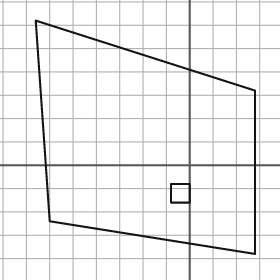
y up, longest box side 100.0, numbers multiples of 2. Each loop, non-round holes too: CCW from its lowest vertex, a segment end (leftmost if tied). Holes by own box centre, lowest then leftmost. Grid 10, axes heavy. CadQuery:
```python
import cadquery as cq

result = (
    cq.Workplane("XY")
    .moveTo(28.0, -38.0)
    .lineTo(28.0, 32.0)
    .lineTo(-66.0, 62.0)
    .lineTo(-60.0, -24.0)
    .close()
    .moveTo(-8.0, -16.0)
    .lineTo(0.0, -16.0)
    .lineTo(0.0, -8.0)
    .lineTo(-8.0, -8.0)
    .close()
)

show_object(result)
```